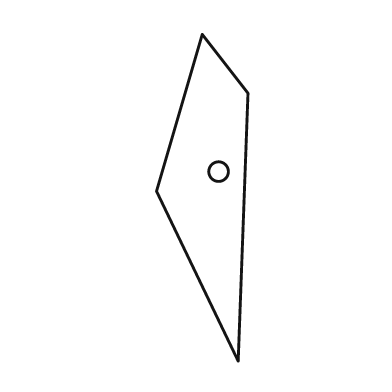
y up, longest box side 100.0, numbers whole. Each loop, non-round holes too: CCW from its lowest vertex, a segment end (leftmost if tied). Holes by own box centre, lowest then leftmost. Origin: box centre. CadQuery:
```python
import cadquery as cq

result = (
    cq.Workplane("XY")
    .moveTo(11.0, -50.0)
    .lineTo(14.0, 32.0)
    .lineTo(0.0, 50.0)
    .lineTo(-14.0, 2.0)
    .close()
    .moveTo(5.0, 8.0)
    .circle(3.0)
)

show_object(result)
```